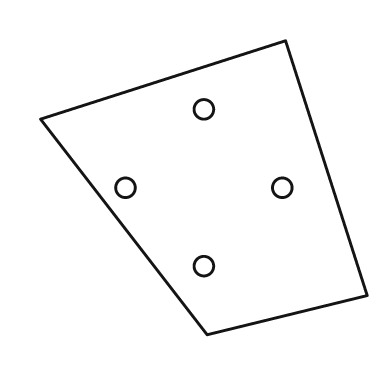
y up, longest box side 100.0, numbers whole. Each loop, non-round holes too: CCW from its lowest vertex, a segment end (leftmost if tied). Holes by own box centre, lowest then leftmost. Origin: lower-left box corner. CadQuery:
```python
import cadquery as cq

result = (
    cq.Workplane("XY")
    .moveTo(51.0, 0.0)
    .lineTo(100.0, 12.0)
    .lineTo(75.0, 90.0)
    .lineTo(0.0, 66.0)
    .close()
    .moveTo(50.0, 21.0)
    .circle(3.0)
    .moveTo(26.0, 45.0)
    .circle(3.0)
    .moveTo(74.0, 45.0)
    .circle(3.0)
    .moveTo(50.0, 69.0)
    .circle(3.0)
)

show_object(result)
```